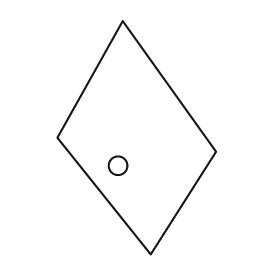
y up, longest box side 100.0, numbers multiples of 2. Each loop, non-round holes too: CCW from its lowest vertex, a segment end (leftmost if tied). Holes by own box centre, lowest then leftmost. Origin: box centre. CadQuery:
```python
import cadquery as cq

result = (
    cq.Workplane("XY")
    .moveTo(6.0, -50.0)
    .lineTo(34.0, -6.0)
    .lineTo(-6.0, 50.0)
    .lineTo(-34.0, 0.0)
    .close()
    .moveTo(-8.0, -12.0)
    .circle(4.0)
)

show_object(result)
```